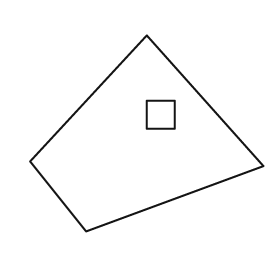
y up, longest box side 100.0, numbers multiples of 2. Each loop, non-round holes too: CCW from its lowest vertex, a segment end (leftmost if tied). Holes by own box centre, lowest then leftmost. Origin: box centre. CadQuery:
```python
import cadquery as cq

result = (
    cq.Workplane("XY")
    .moveTo(-26.0, -42.0)
    .lineTo(50.0, -14.0)
    .lineTo(0.0, 42.0)
    .lineTo(-50.0, -12.0)
    .close()
    .moveTo(0.0, 2.0)
    .lineTo(12.0, 2.0)
    .lineTo(12.0, 14.0)
    .lineTo(0.0, 14.0)
    .close()
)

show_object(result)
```